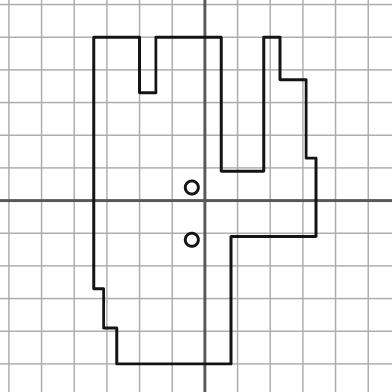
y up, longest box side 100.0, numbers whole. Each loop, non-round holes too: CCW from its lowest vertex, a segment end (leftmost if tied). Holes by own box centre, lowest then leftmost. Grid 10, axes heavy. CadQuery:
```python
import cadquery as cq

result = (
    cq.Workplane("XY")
    .moveTo(-27.0, -50.0)
    .lineTo(8.0, -50.0)
    .lineTo(8.0, -11.0)
    .lineTo(34.0, -11.0)
    .lineTo(34.0, 13.0)
    .lineTo(31.0, 13.0)
    .lineTo(31.0, 37.0)
    .lineTo(23.0, 37.0)
    .lineTo(23.0, 50.0)
    .lineTo(18.0, 50.0)
    .lineTo(18.0, 9.0)
    .lineTo(5.0, 9.0)
    .lineTo(5.0, 50.0)
    .lineTo(-15.0, 50.0)
    .lineTo(-15.0, 33.0)
    .lineTo(-20.0, 33.0)
    .lineTo(-20.0, 50.0)
    .lineTo(-34.0, 50.0)
    .lineTo(-34.0, -27.0)
    .lineTo(-31.0, -27.0)
    .lineTo(-31.0, -39.0)
    .lineTo(-27.0, -39.0)
    .close()
    .moveTo(-4.0, -12.0)
    .circle(2.0)
    .moveTo(-4.0, 4.0)
    .circle(2.0)
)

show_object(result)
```